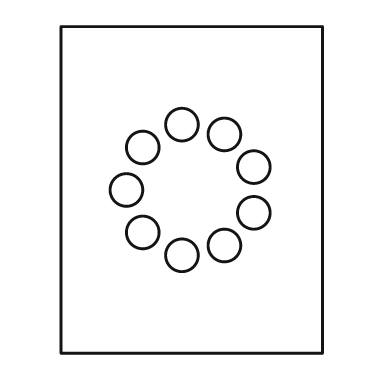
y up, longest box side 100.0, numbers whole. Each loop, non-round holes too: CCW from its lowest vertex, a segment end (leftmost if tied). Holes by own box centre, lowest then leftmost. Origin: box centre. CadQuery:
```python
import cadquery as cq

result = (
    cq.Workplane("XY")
    .moveTo(-40.0, -50.0)
    .lineTo(40.0, -50.0)
    .lineTo(40.0, 50.0)
    .lineTo(-40.0, 50.0)
    .close()
    .moveTo(-3.0, -20.0)
    .circle(5.0)
    .moveTo(10.0, -17.0)
    .circle(5.0)
    .moveTo(-15.0, -13.0)
    .circle(5.0)
    .moveTo(19.0, -7.0)
    .circle(5.0)
    .moveTo(-20.0, 0.0)
    .circle(5.0)
    .moveTo(19.0, 7.0)
    .circle(5.0)
    .moveTo(-15.0, 13.0)
    .circle(5.0)
    .moveTo(10.0, 17.0)
    .circle(5.0)
    .moveTo(-3.0, 20.0)
    .circle(5.0)
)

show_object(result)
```